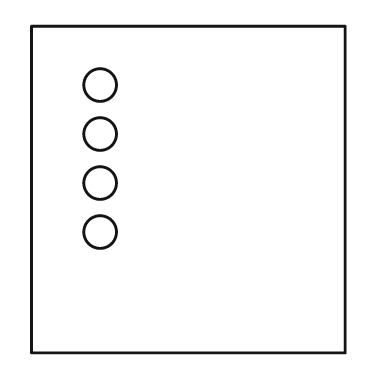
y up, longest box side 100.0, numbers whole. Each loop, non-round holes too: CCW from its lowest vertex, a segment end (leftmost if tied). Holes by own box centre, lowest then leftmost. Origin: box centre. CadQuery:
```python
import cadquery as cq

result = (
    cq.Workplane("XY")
    .moveTo(-48.0, -50.0)
    .lineTo(48.0, -50.0)
    .lineTo(48.0, 50.0)
    .lineTo(-48.0, 50.0)
    .close()
    .moveTo(-27.0, -13.0)
    .circle(5.0)
    .moveTo(-27.0, 2.0)
    .circle(5.0)
    .moveTo(-27.0, 17.0)
    .circle(5.0)
    .moveTo(-27.0, 32.0)
    .circle(5.0)
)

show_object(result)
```